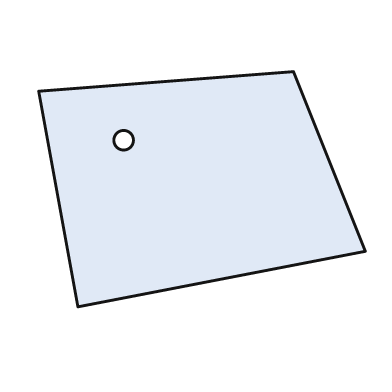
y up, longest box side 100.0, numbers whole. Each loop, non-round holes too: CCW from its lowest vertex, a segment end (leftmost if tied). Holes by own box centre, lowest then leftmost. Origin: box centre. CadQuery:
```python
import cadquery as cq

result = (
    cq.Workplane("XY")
    .moveTo(-38.0, -36.0)
    .lineTo(50.0, -19.0)
    .lineTo(28.0, 36.0)
    .lineTo(-50.0, 30.0)
    .close()
    .moveTo(-24.0, 15.0)
    .circle(3.0)
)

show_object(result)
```